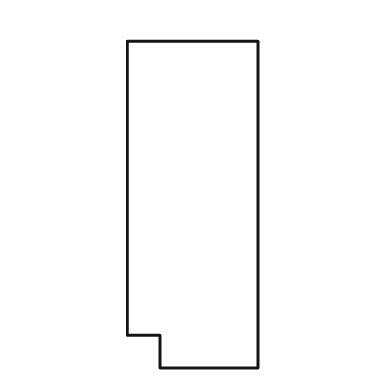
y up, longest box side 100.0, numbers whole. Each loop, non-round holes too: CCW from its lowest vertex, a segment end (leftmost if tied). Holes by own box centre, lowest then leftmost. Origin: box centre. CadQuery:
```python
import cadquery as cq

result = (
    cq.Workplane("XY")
    .moveTo(-10.0, -50.0)
    .lineTo(20.0, -50.0)
    .lineTo(20.0, 50.0)
    .lineTo(-20.0, 50.0)
    .lineTo(-20.0, -40.0)
    .lineTo(-10.0, -40.0)
    .close()
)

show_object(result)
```